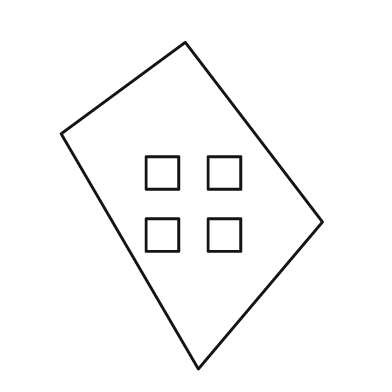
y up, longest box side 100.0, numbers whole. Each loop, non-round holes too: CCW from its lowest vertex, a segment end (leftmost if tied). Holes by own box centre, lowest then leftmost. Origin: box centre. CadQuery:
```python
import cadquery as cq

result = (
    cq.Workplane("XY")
    .moveTo(2.0, -50.0)
    .lineTo(40.0, -5.0)
    .lineTo(-2.0, 50.0)
    .lineTo(-40.0, 22.0)
    .close()
    .moveTo(-14.0, -14.0)
    .lineTo(-4.0, -14.0)
    .lineTo(-4.0, -4.0)
    .lineTo(-14.0, -4.0)
    .close()
    .moveTo(5.0, -14.0)
    .lineTo(15.0, -14.0)
    .lineTo(15.0, -4.0)
    .lineTo(5.0, -4.0)
    .close()
    .moveTo(-14.0, 5.0)
    .lineTo(-4.0, 5.0)
    .lineTo(-4.0, 15.0)
    .lineTo(-14.0, 15.0)
    .close()
    .moveTo(5.0, 5.0)
    .lineTo(15.0, 5.0)
    .lineTo(15.0, 15.0)
    .lineTo(5.0, 15.0)
    .close()
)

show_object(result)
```